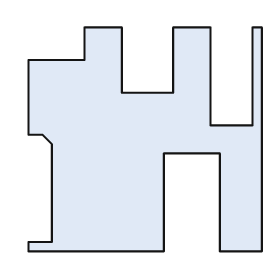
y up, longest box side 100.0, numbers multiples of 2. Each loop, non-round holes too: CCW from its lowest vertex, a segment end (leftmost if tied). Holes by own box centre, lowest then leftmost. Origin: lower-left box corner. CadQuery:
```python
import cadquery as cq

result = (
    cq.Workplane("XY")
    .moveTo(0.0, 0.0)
    .lineTo(58.0, 0.0)
    .lineTo(58.0, 42.0)
    .lineTo(82.0, 42.0)
    .lineTo(82.0, 0.0)
    .lineTo(100.0, 0.0)
    .lineTo(100.0, 96.0)
    .lineTo(96.0, 96.0)
    .lineTo(96.0, 54.0)
    .lineTo(78.0, 54.0)
    .lineTo(78.0, 96.0)
    .lineTo(62.0, 96.0)
    .lineTo(62.0, 68.0)
    .lineTo(40.0, 68.0)
    .lineTo(40.0, 96.0)
    .lineTo(24.0, 96.0)
    .lineTo(24.0, 82.0)
    .lineTo(0.0, 82.0)
    .lineTo(0.0, 50.0)
    .lineTo(6.0, 50.0)
    .lineTo(10.0, 46.0)
    .lineTo(10.0, 4.0)
    .lineTo(0.0, 4.0)
    .close()
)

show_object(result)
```